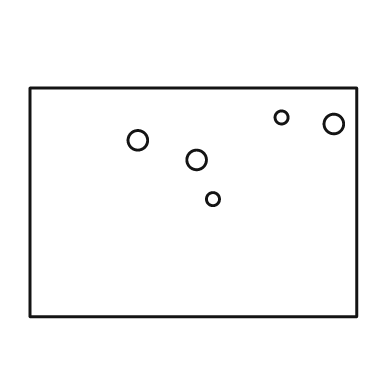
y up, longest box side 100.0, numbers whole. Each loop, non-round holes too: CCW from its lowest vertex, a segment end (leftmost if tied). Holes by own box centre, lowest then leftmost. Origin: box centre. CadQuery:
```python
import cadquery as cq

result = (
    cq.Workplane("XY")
    .moveTo(-50.0, -35.0)
    .lineTo(50.0, -35.0)
    .lineTo(50.0, 35.0)
    .lineTo(-50.0, 35.0)
    .close()
    .moveTo(6.0, 1.0)
    .circle(2.0)
    .moveTo(1.0, 13.0)
    .circle(3.0)
    .moveTo(-17.0, 19.0)
    .circle(3.0)
    .moveTo(43.0, 24.0)
    .circle(3.0)
    .moveTo(27.0, 26.0)
    .circle(2.0)
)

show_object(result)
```